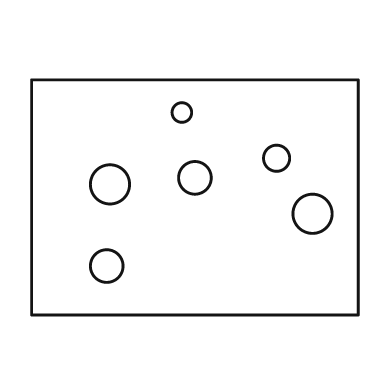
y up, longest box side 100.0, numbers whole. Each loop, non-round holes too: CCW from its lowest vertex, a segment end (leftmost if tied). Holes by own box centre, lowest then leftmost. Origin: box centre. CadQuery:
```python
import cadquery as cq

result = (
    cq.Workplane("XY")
    .moveTo(-50.0, -36.0)
    .lineTo(50.0, -36.0)
    .lineTo(50.0, 36.0)
    .lineTo(-50.0, 36.0)
    .close()
    .moveTo(-27.0, -21.0)
    .circle(5.0)
    .moveTo(36.0, -5.0)
    .circle(6.0)
    .moveTo(-26.0, 4.0)
    .circle(6.0)
    .moveTo(0.0, 6.0)
    .circle(5.0)
    .moveTo(25.0, 12.0)
    .circle(4.0)
    .moveTo(-4.0, 26.0)
    .circle(3.0)
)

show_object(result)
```